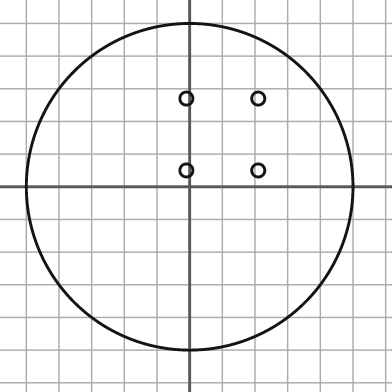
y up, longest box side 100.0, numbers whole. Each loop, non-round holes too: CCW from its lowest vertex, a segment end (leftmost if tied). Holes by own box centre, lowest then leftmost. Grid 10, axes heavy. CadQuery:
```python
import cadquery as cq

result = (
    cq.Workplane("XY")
    .moveTo(0.0, 0.0)
    .circle(50.0)
    .moveTo(-1.0, 5.0)
    .circle(2.0)
    .moveTo(21.0, 5.0)
    .circle(2.0)
    .moveTo(-1.0, 27.0)
    .circle(2.0)
    .moveTo(21.0, 27.0)
    .circle(2.0)
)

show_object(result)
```